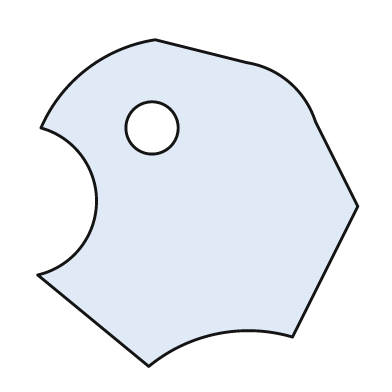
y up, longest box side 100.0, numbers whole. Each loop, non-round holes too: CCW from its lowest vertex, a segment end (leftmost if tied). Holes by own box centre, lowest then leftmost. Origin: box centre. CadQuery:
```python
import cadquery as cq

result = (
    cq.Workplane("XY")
    .moveTo(-15.0, -50.0)
    .threePointArc((6.0, -40.0), (29.0, -41.0))
    .lineTo(49.0, -1.0)
    .lineTo(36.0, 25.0)
    .threePointArc((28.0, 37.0), (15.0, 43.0))
    .lineTo(-13.0, 50.0)
    .threePointArc((-34.0, 41.0), (-48.0, 23.0))
    .threePointArc((-31.0, 0.0), (-49.0, -22.0))
    .close()
    .moveTo(-14.0, 23.0)
    .circle(8.0)
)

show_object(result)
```